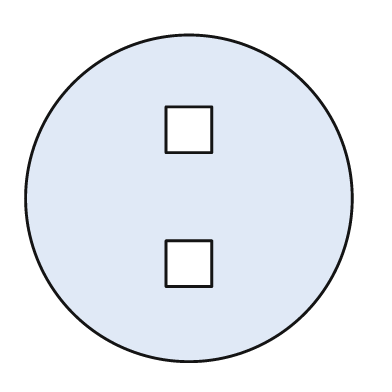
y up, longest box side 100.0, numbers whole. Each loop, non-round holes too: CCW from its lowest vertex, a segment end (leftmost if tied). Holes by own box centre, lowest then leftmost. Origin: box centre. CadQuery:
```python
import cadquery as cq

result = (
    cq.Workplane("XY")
    .moveTo(0.0, 0.0)
    .circle(50.0)
    .moveTo(-7.0, -27.0)
    .lineTo(7.0, -27.0)
    .lineTo(7.0, -13.0)
    .lineTo(-7.0, -13.0)
    .close()
    .moveTo(-7.0, 14.0)
    .lineTo(7.0, 14.0)
    .lineTo(7.0, 28.0)
    .lineTo(-7.0, 28.0)
    .close()
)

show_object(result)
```